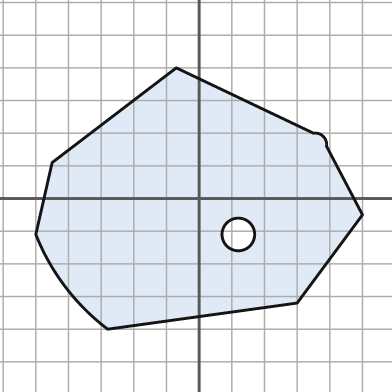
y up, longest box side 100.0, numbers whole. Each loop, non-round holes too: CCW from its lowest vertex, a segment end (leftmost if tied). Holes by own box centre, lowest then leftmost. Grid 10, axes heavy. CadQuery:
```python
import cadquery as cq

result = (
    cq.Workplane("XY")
    .moveTo(-28.0, -40.0)
    .lineTo(30.0, -32.0)
    .lineTo(50.0, -5.0)
    .lineTo(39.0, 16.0)
    .threePointArc((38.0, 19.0), (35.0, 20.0))
    .lineTo(-7.0, 40.0)
    .lineTo(-45.0, 11.0)
    .lineTo(-50.0, -11.0)
    .threePointArc((-41.0, -27.0), (-28.0, -40.0))
    .close()
    .moveTo(12.0, -11.0)
    .circle(5.0)
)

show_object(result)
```